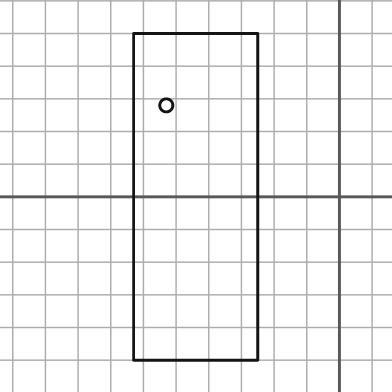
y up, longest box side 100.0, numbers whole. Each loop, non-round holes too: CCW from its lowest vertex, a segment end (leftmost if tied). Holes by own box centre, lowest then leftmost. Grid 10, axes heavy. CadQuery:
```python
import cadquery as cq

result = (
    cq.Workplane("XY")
    .moveTo(-63.0, -50.0)
    .lineTo(-25.0, -50.0)
    .lineTo(-25.0, 50.0)
    .lineTo(-63.0, 50.0)
    .close()
    .moveTo(-53.0, 28.0)
    .circle(2.0)
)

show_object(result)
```